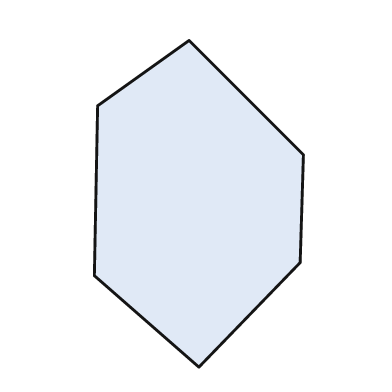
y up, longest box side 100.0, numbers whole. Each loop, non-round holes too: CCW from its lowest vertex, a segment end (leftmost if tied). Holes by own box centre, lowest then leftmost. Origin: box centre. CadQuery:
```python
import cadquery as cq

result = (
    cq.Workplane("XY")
    .moveTo(0.0, -50.0)
    .lineTo(31.0, -18.0)
    .lineTo(32.0, 15.0)
    .lineTo(-3.0, 50.0)
    .lineTo(-31.0, 30.0)
    .lineTo(-32.0, -22.0)
    .close()
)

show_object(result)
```